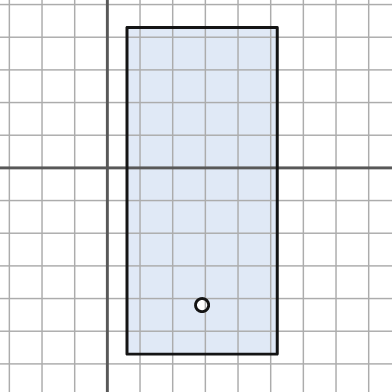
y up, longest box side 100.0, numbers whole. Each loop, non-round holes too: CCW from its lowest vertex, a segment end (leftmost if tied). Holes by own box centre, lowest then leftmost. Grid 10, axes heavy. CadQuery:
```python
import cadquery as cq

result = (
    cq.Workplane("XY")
    .moveTo(6.0, -57.0)
    .lineTo(52.0, -57.0)
    .lineTo(52.0, 43.0)
    .lineTo(6.0, 43.0)
    .close()
    .moveTo(29.0, -42.0)
    .circle(2.0)
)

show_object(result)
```